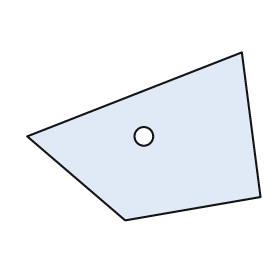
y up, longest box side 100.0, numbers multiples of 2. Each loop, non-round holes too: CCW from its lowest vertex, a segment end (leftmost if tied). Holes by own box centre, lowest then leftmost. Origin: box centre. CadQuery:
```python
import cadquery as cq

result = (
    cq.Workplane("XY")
    .moveTo(-8.0, -36.0)
    .lineTo(50.0, -26.0)
    .lineTo(42.0, 36.0)
    .lineTo(-50.0, 0.0)
    .close()
    .moveTo(0.0, 0.0)
    .circle(4.0)
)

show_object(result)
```